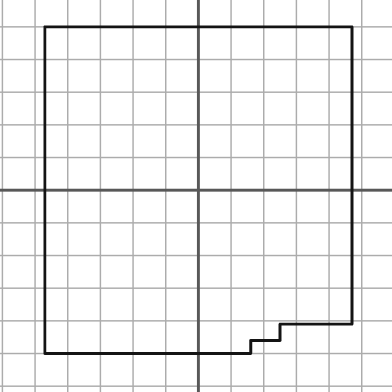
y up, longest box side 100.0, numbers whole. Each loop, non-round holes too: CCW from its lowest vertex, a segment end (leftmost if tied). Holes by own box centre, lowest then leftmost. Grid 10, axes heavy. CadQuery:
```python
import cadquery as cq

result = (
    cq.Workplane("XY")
    .moveTo(-47.0, -50.0)
    .lineTo(16.0, -50.0)
    .lineTo(16.0, -46.0)
    .lineTo(25.0, -46.0)
    .lineTo(25.0, -41.0)
    .lineTo(47.0, -41.0)
    .lineTo(47.0, 50.0)
    .lineTo(-47.0, 50.0)
    .close()
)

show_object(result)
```